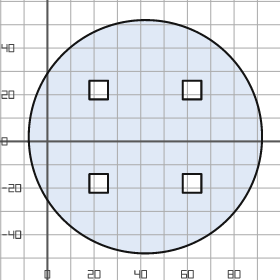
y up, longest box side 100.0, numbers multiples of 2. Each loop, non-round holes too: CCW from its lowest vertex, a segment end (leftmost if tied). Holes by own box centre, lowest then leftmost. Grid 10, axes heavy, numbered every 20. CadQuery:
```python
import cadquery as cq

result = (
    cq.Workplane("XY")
    .moveTo(42.0, 2.0)
    .circle(50.0)
    .moveTo(18.0, -22.0)
    .lineTo(26.0, -22.0)
    .lineTo(26.0, -14.0)
    .lineTo(18.0, -14.0)
    .close()
    .moveTo(58.0, -22.0)
    .lineTo(66.0, -22.0)
    .lineTo(66.0, -14.0)
    .lineTo(58.0, -14.0)
    .close()
    .moveTo(18.0, 18.0)
    .lineTo(26.0, 18.0)
    .lineTo(26.0, 26.0)
    .lineTo(18.0, 26.0)
    .close()
    .moveTo(58.0, 18.0)
    .lineTo(66.0, 18.0)
    .lineTo(66.0, 26.0)
    .lineTo(58.0, 26.0)
    .close()
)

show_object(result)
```